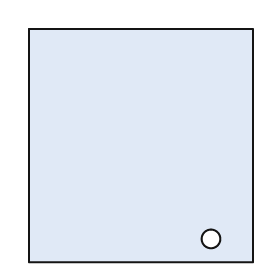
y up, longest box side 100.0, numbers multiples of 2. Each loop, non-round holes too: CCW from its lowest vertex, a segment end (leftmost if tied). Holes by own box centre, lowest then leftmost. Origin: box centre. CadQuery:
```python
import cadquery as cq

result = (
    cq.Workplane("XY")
    .moveTo(-48.0, -50.0)
    .lineTo(48.0, -50.0)
    .lineTo(48.0, 50.0)
    .lineTo(-48.0, 50.0)
    .close()
    .moveTo(30.0, -40.0)
    .circle(4.0)
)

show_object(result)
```